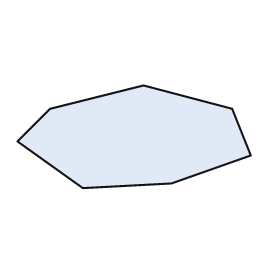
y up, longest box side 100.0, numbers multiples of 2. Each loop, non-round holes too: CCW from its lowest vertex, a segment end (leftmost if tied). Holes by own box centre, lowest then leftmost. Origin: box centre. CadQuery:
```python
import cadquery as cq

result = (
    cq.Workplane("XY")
    .moveTo(-22.0, -22.0)
    .lineTo(16.0, -20.0)
    .lineTo(50.0, -8.0)
    .lineTo(42.0, 12.0)
    .lineTo(4.0, 22.0)
    .lineTo(-36.0, 12.0)
    .lineTo(-50.0, -2.0)
    .close()
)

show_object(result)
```